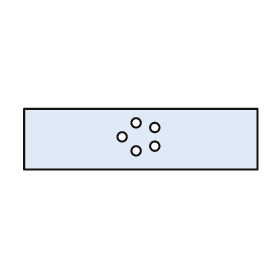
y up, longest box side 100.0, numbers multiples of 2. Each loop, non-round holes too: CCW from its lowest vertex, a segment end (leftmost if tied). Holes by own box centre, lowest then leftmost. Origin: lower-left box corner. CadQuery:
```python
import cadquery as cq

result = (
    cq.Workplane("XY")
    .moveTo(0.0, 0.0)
    .lineTo(100.0, 0.0)
    .lineTo(100.0, 26.0)
    .lineTo(0.0, 26.0)
    .close()
    .moveTo(48.0, 8.0)
    .circle(2.0)
    .moveTo(56.0, 10.0)
    .circle(2.0)
    .moveTo(42.0, 14.0)
    .circle(2.0)
    .moveTo(56.0, 18.0)
    .circle(2.0)
    .moveTo(48.0, 20.0)
    .circle(2.0)
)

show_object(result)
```